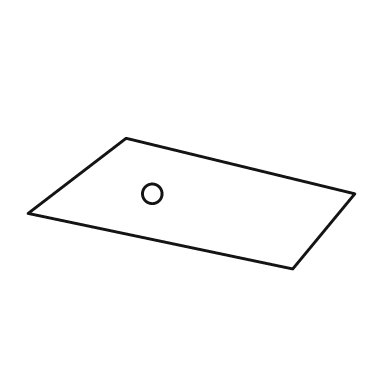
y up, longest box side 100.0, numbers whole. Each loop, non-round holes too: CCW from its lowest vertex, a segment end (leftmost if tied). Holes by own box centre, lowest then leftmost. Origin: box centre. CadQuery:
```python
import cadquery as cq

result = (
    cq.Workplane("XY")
    .moveTo(31.0, -20.0)
    .lineTo(50.0, 3.0)
    .lineTo(-20.0, 20.0)
    .lineTo(-50.0, -3.0)
    .close()
    .moveTo(-12.0, 3.0)
    .circle(3.0)
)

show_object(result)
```